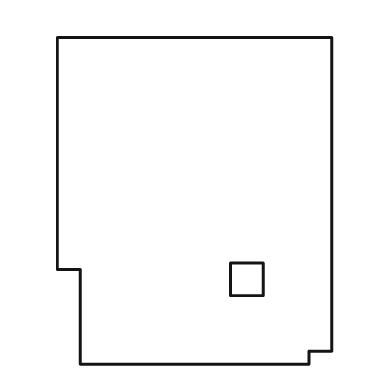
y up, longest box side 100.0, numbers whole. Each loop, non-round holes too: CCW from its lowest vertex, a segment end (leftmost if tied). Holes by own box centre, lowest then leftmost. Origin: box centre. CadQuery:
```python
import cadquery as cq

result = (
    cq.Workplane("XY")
    .moveTo(-35.0, -50.0)
    .lineTo(35.0, -50.0)
    .lineTo(35.0, -46.0)
    .lineTo(42.0, -46.0)
    .lineTo(42.0, 50.0)
    .lineTo(-42.0, 50.0)
    .lineTo(-42.0, -21.0)
    .lineTo(-35.0, -21.0)
    .close()
    .moveTo(11.0, -29.0)
    .lineTo(21.0, -29.0)
    .lineTo(21.0, -19.0)
    .lineTo(11.0, -19.0)
    .close()
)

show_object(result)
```